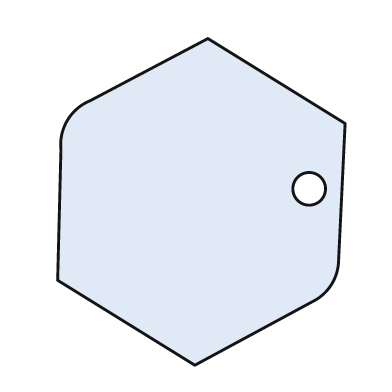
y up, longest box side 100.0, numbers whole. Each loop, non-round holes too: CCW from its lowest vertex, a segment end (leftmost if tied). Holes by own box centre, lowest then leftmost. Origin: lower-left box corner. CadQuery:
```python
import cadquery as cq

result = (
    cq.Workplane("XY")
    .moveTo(42.0, 0.0)
    .lineTo(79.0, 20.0)
    .threePointArc((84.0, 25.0), (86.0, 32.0))
    .lineTo(88.0, 74.0)
    .lineTo(46.0, 100.0)
    .lineTo(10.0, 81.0)
    .threePointArc((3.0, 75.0), (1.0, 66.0))
    .lineTo(0.0, 26.0)
    .close()
    .moveTo(77.0, 54.0)
    .circle(5.0)
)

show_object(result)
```